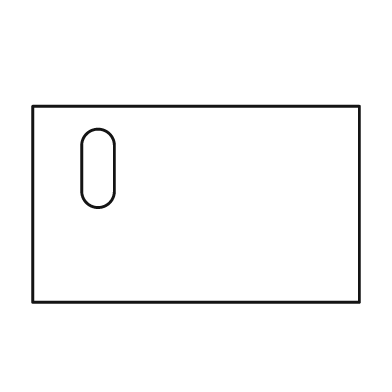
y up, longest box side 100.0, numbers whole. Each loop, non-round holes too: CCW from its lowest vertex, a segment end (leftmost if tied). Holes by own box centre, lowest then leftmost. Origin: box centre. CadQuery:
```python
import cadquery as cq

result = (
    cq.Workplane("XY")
    .moveTo(-50.0, -30.0)
    .lineTo(50.0, -30.0)
    .lineTo(50.0, 30.0)
    .lineTo(-50.0, 30.0)
    .close()
    .moveTo(-35.0, 4.0)
    .threePointArc((-30.0, -1.0), (-25.0, 4.0))
    .lineTo(-25.0, 18.0)
    .threePointArc((-30.0, 23.0), (-35.0, 18.0))
    .close()
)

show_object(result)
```